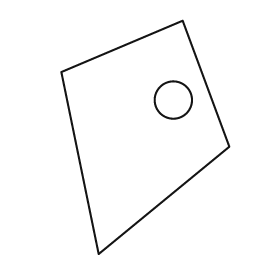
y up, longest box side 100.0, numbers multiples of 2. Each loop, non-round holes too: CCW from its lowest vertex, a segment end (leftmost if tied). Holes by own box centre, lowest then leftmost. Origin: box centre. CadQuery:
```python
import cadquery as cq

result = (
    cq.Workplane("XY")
    .moveTo(-20.0, -50.0)
    .lineTo(36.0, -4.0)
    .lineTo(16.0, 50.0)
    .lineTo(-36.0, 28.0)
    .close()
    .moveTo(12.0, 16.0)
    .circle(8.0)
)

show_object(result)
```